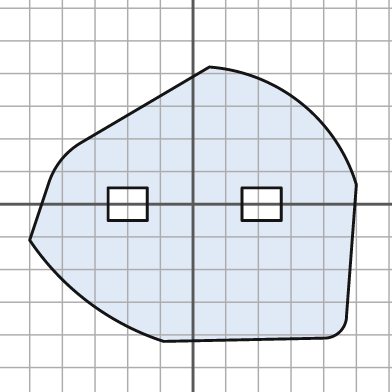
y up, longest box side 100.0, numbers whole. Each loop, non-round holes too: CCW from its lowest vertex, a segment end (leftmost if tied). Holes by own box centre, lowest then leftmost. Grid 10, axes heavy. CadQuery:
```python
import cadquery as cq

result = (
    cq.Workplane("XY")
    .moveTo(-9.0, -42.0)
    .lineTo(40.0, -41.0)
    .threePointArc((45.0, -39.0), (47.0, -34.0))
    .lineTo(50.0, 6.0)
    .threePointArc((33.0, 31.0), (5.0, 42.0))
    .lineTo(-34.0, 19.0)
    .threePointArc((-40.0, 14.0), (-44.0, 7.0))
    .lineTo(-50.0, -11.0)
    .threePointArc((-32.0, -30.0), (-9.0, -42.0))
    .close()
    .moveTo(-26.0, -5.0)
    .lineTo(-14.0, -5.0)
    .lineTo(-14.0, 5.0)
    .lineTo(-26.0, 5.0)
    .close()
    .moveTo(15.0, -5.0)
    .lineTo(27.0, -5.0)
    .lineTo(27.0, 5.0)
    .lineTo(15.0, 5.0)
    .close()
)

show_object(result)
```